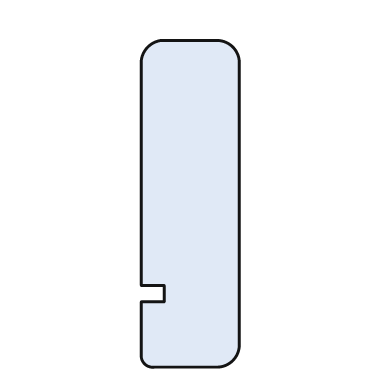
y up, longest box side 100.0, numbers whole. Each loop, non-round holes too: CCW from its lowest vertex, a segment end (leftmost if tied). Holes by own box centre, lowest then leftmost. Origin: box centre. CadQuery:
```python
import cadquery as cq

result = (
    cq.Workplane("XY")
    .moveTo(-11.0, -50.0)
    .lineTo(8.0, -50.0)
    .threePointArc((13.0, -48.0), (15.0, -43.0))
    .lineTo(15.0, 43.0)
    .threePointArc((13.0, 48.0), (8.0, 50.0))
    .lineTo(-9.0, 50.0)
    .threePointArc((-13.0, 48.0), (-15.0, 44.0))
    .lineTo(-15.0, -25.0)
    .lineTo(-8.0, -25.0)
    .lineTo(-8.0, -30.0)
    .lineTo(-15.0, -30.0)
    .lineTo(-15.0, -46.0)
    .threePointArc((-14.0, -49.0), (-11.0, -50.0))
    .close()
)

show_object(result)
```